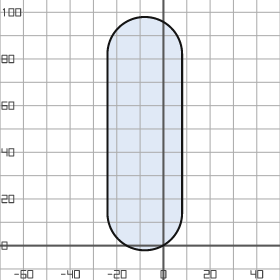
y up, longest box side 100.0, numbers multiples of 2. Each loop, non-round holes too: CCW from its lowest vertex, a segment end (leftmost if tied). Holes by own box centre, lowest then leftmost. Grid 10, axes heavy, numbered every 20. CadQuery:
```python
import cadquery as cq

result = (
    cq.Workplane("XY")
    .moveTo(-24.0, 14.0)
    .threePointArc((-8.0, -2.0), (8.0, 14.0))
    .lineTo(8.0, 82.0)
    .threePointArc((-8.0, 98.0), (-24.0, 82.0))
    .close()
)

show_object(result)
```